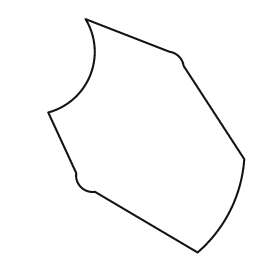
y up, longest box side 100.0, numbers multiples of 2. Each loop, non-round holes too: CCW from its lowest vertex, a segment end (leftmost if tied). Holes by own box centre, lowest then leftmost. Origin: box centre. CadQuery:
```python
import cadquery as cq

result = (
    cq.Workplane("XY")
    .moveTo(22.0, -50.0)
    .threePointArc((36.0, -32.0), (42.0, -10.0))
    .lineTo(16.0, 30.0)
    .threePointArc((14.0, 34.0), (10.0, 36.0))
    .lineTo(-26.0, 50.0)
    .threePointArc((-24.0, 26.0), (-42.0, 10.0))
    .lineTo(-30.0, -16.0)
    .threePointArc((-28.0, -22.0), (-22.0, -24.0))
    .close()
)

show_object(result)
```